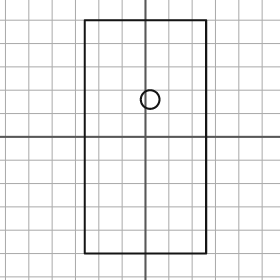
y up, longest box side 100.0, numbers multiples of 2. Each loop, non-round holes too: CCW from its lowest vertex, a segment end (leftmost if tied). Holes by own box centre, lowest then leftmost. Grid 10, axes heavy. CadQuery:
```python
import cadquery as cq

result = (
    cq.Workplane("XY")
    .moveTo(-26.0, -50.0)
    .lineTo(26.0, -50.0)
    .lineTo(26.0, 50.0)
    .lineTo(-26.0, 50.0)
    .close()
    .moveTo(2.0, 16.0)
    .circle(4.0)
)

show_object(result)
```